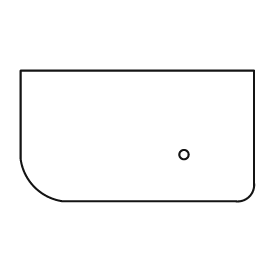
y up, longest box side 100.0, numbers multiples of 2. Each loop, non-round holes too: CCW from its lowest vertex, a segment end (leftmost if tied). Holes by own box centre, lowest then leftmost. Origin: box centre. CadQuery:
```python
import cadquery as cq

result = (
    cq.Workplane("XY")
    .moveTo(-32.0, -28.0)
    .lineTo(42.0, -28.0)
    .threePointArc((48.0, -26.0), (50.0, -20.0))
    .lineTo(50.0, 28.0)
    .lineTo(-50.0, 28.0)
    .lineTo(-50.0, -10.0)
    .threePointArc((-44.0, -22.0), (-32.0, -28.0))
    .close()
    .moveTo(20.0, -8.0)
    .circle(2.0)
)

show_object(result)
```